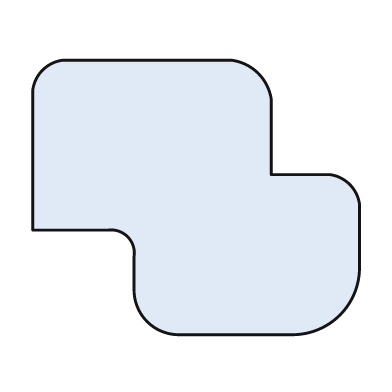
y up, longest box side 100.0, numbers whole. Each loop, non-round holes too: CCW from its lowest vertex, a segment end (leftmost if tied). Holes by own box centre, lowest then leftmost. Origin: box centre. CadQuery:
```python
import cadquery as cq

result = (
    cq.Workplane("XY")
    .moveTo(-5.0, -42.0)
    .lineTo(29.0, -42.0)
    .threePointArc((44.0, -36.0), (50.0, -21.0))
    .lineTo(50.0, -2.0)
    .threePointArc((47.0, 4.0), (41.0, 7.0))
    .lineTo(23.0, 7.0)
    .lineTo(23.0, 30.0)
    .threePointArc((19.0, 38.0), (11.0, 42.0))
    .lineTo(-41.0, 42.0)
    .threePointArc((-47.0, 39.0), (-50.0, 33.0))
    .lineTo(-50.0, -10.0)
    .lineTo(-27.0, -10.0)
    .threePointArc((-21.0, -12.0), (-19.0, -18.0))
    .lineTo(-19.0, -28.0)
    .threePointArc((-15.0, -38.0), (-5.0, -42.0))
    .close()
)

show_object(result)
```